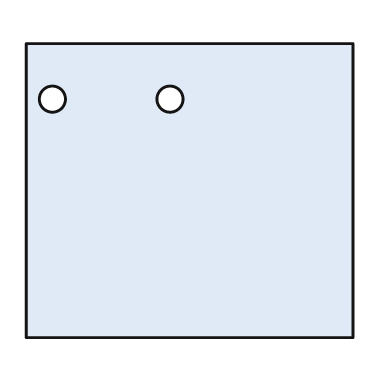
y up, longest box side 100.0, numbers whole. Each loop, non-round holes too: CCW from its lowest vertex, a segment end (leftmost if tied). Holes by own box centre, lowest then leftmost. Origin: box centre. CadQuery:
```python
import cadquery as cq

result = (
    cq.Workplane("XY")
    .moveTo(-50.0, -45.0)
    .lineTo(50.0, -45.0)
    .lineTo(50.0, 45.0)
    .lineTo(-50.0, 45.0)
    .close()
    .moveTo(-42.0, 28.0)
    .circle(4.0)
    .moveTo(-6.0, 28.0)
    .circle(4.0)
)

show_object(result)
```